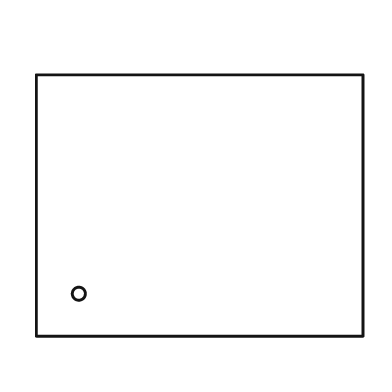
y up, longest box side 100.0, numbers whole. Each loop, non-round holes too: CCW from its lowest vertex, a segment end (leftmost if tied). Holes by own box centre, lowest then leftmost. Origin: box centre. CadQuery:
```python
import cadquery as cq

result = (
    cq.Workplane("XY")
    .moveTo(-50.0, -40.0)
    .lineTo(50.0, -40.0)
    .lineTo(50.0, 40.0)
    .lineTo(-50.0, 40.0)
    .close()
    .moveTo(-37.0, -27.0)
    .circle(2.0)
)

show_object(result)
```